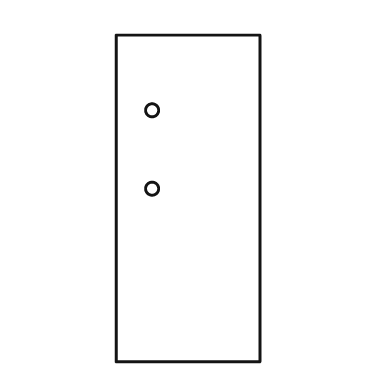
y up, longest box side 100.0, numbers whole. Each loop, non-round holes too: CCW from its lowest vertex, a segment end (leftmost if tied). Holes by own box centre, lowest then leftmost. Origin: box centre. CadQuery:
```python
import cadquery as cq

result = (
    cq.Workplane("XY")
    .moveTo(-22.0, -50.0)
    .lineTo(22.0, -50.0)
    .lineTo(22.0, 50.0)
    .lineTo(-22.0, 50.0)
    .close()
    .moveTo(-11.0, 3.0)
    .circle(2.0)
    .moveTo(-11.0, 27.0)
    .circle(2.0)
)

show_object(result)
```